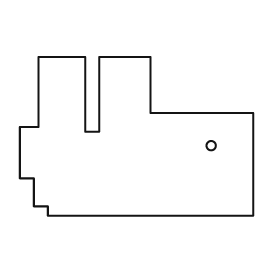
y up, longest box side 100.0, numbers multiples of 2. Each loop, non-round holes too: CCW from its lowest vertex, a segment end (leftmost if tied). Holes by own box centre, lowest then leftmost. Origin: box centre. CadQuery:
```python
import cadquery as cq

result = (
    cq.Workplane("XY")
    .moveTo(-38.0, -34.0)
    .lineTo(50.0, -34.0)
    .lineTo(50.0, 10.0)
    .lineTo(6.0, 10.0)
    .lineTo(6.0, 34.0)
    .lineTo(-16.0, 34.0)
    .lineTo(-16.0, 2.0)
    .lineTo(-22.0, 2.0)
    .lineTo(-22.0, 34.0)
    .lineTo(-42.0, 34.0)
    .lineTo(-42.0, 4.0)
    .lineTo(-50.0, 4.0)
    .lineTo(-50.0, -18.0)
    .lineTo(-44.0, -18.0)
    .lineTo(-44.0, -30.0)
    .lineTo(-38.0, -30.0)
    .close()
    .moveTo(32.0, -4.0)
    .circle(2.0)
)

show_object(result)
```